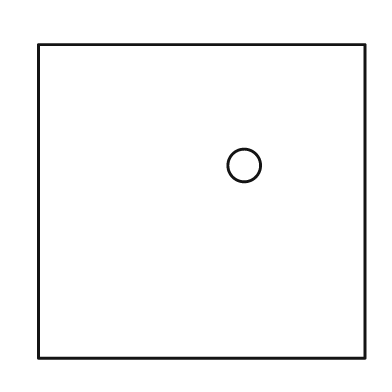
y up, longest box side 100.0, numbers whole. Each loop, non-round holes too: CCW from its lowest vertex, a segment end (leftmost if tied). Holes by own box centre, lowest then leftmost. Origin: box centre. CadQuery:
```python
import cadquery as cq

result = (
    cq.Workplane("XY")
    .moveTo(-50.0, -48.0)
    .lineTo(50.0, -48.0)
    .lineTo(50.0, 48.0)
    .lineTo(-50.0, 48.0)
    .close()
    .moveTo(13.0, 11.0)
    .circle(5.0)
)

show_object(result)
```